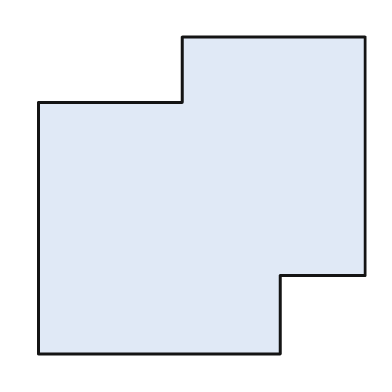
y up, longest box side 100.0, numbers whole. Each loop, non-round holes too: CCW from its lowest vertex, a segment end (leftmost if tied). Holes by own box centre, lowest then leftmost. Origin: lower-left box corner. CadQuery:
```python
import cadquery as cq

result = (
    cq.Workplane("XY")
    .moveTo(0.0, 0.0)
    .lineTo(74.0, 0.0)
    .lineTo(74.0, 24.0)
    .lineTo(100.0, 24.0)
    .lineTo(100.0, 97.0)
    .lineTo(44.0, 97.0)
    .lineTo(44.0, 77.0)
    .lineTo(0.0, 77.0)
    .close()
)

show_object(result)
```